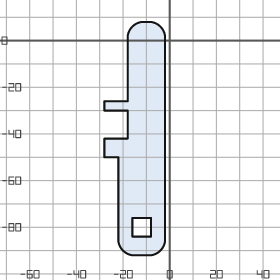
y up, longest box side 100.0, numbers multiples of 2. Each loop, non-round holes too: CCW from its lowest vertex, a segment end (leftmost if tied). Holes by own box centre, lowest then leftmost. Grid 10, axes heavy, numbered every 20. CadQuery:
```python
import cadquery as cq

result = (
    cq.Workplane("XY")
    .moveTo(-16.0, -92.0)
    .lineTo(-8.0, -92.0)
    .threePointArc((-4.0, -90.0), (-2.0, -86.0))
    .lineTo(-2.0, 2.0)
    .threePointArc((-4.0, 6.0), (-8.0, 8.0))
    .lineTo(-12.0, 8.0)
    .threePointArc((-16.0, 6.0), (-18.0, 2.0))
    .lineTo(-18.0, -26.0)
    .lineTo(-28.0, -26.0)
    .lineTo(-28.0, -30.0)
    .lineTo(-18.0, -30.0)
    .lineTo(-18.0, -42.0)
    .lineTo(-28.0, -42.0)
    .lineTo(-28.0, -50.0)
    .lineTo(-22.0, -50.0)
    .lineTo(-22.0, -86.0)
    .threePointArc((-20.0, -90.0), (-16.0, -92.0))
    .close()
    .moveTo(-16.0, -84.0)
    .lineTo(-8.0, -84.0)
    .lineTo(-8.0, -76.0)
    .lineTo(-16.0, -76.0)
    .close()
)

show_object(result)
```